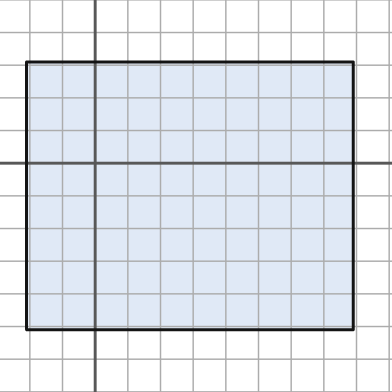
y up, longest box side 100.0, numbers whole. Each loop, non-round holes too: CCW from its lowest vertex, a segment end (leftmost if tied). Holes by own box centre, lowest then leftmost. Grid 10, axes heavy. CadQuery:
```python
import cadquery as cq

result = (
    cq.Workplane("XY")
    .moveTo(-21.0, -51.0)
    .lineTo(79.0, -51.0)
    .lineTo(79.0, 31.0)
    .lineTo(-21.0, 31.0)
    .close()
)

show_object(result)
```